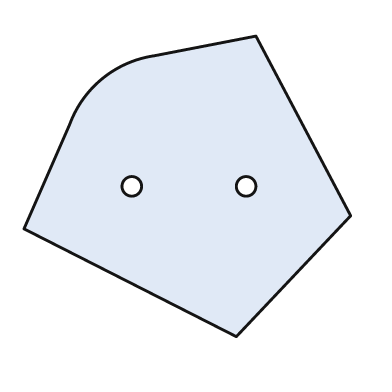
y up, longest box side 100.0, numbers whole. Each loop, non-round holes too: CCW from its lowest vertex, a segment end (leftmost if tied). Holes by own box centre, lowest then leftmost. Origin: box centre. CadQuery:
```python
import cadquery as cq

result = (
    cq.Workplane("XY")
    .moveTo(15.0, -46.0)
    .lineTo(50.0, -9.0)
    .lineTo(21.0, 46.0)
    .lineTo(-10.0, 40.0)
    .threePointArc((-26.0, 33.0), (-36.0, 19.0))
    .lineTo(-50.0, -13.0)
    .close()
    .moveTo(-17.0, 0.0)
    .circle(3.0)
    .moveTo(18.0, 0.0)
    .circle(3.0)
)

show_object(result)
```